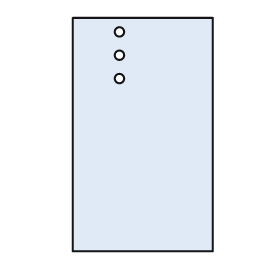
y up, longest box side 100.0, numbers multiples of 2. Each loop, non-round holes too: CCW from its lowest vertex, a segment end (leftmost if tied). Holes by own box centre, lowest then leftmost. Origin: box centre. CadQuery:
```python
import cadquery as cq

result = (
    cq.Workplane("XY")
    .moveTo(-30.0, -50.0)
    .lineTo(30.0, -50.0)
    .lineTo(30.0, 50.0)
    .lineTo(-30.0, 50.0)
    .close()
    .moveTo(-10.0, 24.0)
    .circle(2.0)
    .moveTo(-10.0, 34.0)
    .circle(2.0)
    .moveTo(-10.0, 44.0)
    .circle(2.0)
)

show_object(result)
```